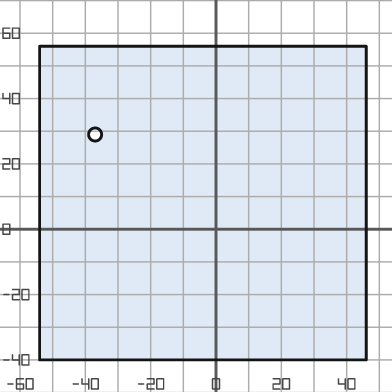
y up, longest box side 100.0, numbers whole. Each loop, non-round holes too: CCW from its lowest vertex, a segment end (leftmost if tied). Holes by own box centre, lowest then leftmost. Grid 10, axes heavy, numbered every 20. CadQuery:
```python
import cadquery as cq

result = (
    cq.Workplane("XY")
    .moveTo(-54.0, -40.0)
    .lineTo(46.0, -40.0)
    .lineTo(46.0, 56.0)
    .lineTo(-54.0, 56.0)
    .close()
    .moveTo(-37.0, 29.0)
    .circle(2.0)
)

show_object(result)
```